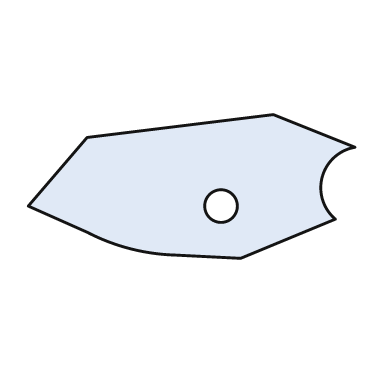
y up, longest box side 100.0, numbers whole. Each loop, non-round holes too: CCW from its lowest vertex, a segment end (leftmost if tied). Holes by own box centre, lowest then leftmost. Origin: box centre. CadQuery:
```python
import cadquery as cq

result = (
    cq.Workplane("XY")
    .moveTo(15.0, -22.0)
    .lineTo(44.0, -10.0)
    .threePointArc((40.0, 3.0), (50.0, 12.0))
    .lineTo(25.0, 22.0)
    .lineTo(-32.0, 15.0)
    .lineTo(-50.0, -6.0)
    .lineTo(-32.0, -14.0)
    .threePointArc((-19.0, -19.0), (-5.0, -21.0))
    .close()
    .moveTo(9.0, -6.0)
    .circle(5.0)
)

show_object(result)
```